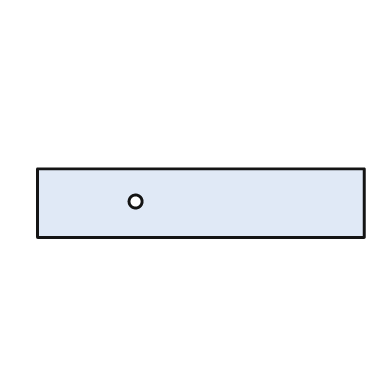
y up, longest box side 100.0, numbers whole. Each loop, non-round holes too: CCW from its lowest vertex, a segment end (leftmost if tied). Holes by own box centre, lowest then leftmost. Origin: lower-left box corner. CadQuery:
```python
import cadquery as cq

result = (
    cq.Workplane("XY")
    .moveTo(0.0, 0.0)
    .lineTo(100.0, 0.0)
    .lineTo(100.0, 21.0)
    .lineTo(0.0, 21.0)
    .close()
    .moveTo(30.0, 11.0)
    .circle(2.0)
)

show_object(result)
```